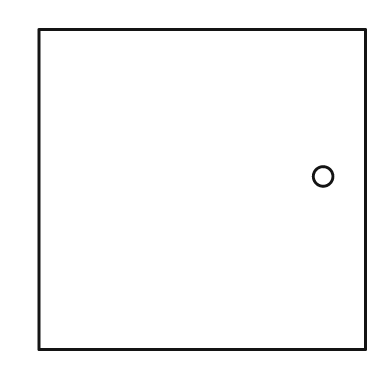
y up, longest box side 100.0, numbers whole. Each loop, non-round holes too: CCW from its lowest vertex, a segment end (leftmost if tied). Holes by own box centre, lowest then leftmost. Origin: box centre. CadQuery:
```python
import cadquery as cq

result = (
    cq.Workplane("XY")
    .moveTo(-50.0, -49.0)
    .lineTo(50.0, -49.0)
    .lineTo(50.0, 49.0)
    .lineTo(-50.0, 49.0)
    .close()
    .moveTo(37.0, 4.0)
    .circle(3.0)
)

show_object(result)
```